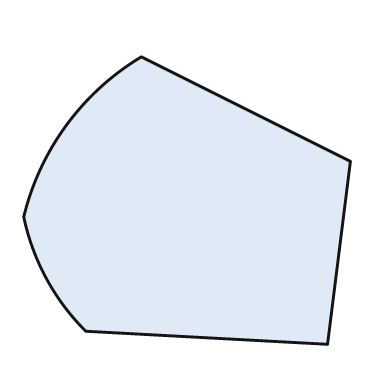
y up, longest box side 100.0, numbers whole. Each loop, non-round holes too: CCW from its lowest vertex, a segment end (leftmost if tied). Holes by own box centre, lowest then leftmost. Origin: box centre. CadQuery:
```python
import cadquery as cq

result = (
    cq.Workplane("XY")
    .moveTo(43.0, -44.0)
    .lineTo(50.0, 12.0)
    .lineTo(-14.0, 44.0)
    .threePointArc((-37.0, 23.0), (-50.0, -5.0))
    .threePointArc((-43.0, -24.0), (-31.0, -40.0))
    .close()
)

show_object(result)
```